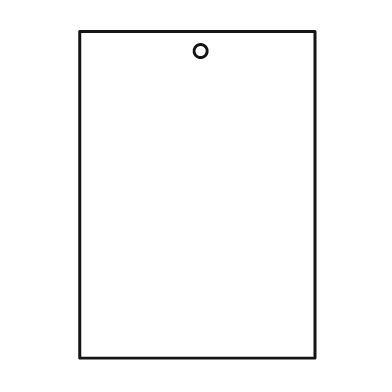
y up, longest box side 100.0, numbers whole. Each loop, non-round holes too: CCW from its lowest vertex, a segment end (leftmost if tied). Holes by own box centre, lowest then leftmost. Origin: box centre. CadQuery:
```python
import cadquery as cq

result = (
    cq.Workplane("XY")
    .moveTo(-36.0, -50.0)
    .lineTo(36.0, -50.0)
    .lineTo(36.0, 50.0)
    .lineTo(-36.0, 50.0)
    .close()
    .moveTo(1.0, 44.0)
    .circle(2.0)
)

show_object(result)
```